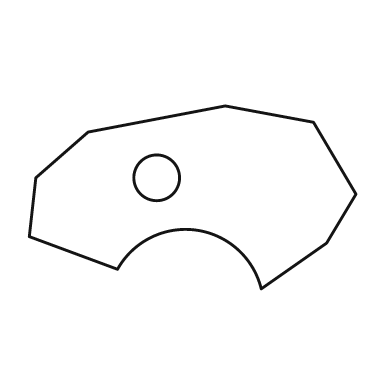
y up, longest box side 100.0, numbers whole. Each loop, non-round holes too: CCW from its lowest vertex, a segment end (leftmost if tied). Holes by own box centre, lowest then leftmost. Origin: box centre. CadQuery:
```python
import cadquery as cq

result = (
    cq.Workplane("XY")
    .moveTo(21.0, -28.0)
    .lineTo(41.0, -14.0)
    .lineTo(50.0, 1.0)
    .lineTo(37.0, 23.0)
    .lineTo(10.0, 28.0)
    .lineTo(-32.0, 20.0)
    .lineTo(-48.0, 6.0)
    .lineTo(-50.0, -12.0)
    .lineTo(-23.0, -22.0)
    .threePointArc((1.0, -10.0), (21.0, -28.0))
    .close()
    .moveTo(-11.0, 6.0)
    .circle(7.0)
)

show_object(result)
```